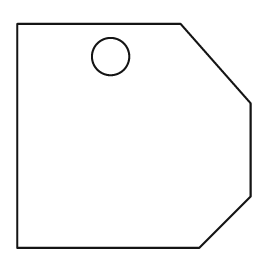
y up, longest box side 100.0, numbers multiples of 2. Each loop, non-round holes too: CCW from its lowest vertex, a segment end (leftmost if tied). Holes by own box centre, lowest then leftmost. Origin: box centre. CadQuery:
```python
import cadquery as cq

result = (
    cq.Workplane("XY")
    .moveTo(-50.0, -48.0)
    .lineTo(28.0, -48.0)
    .lineTo(50.0, -26.0)
    .lineTo(50.0, 14.0)
    .lineTo(20.0, 48.0)
    .lineTo(-50.0, 48.0)
    .close()
    .moveTo(-10.0, 34.0)
    .circle(8.0)
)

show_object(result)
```